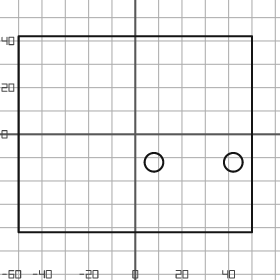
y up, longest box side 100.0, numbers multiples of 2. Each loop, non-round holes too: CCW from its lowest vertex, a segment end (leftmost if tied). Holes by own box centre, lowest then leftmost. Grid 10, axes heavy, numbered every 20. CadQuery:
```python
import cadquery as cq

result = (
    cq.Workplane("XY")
    .moveTo(-50.0, -42.0)
    .lineTo(50.0, -42.0)
    .lineTo(50.0, 42.0)
    .lineTo(-50.0, 42.0)
    .close()
    .moveTo(8.0, -12.0)
    .circle(4.0)
    .moveTo(42.0, -12.0)
    .circle(4.0)
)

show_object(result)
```